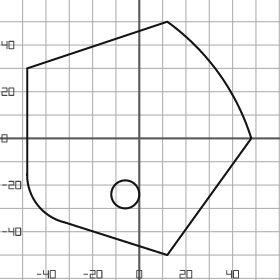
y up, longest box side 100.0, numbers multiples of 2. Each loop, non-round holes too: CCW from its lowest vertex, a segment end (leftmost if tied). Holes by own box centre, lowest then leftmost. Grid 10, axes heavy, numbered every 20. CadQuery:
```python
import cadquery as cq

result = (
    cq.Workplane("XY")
    .moveTo(12.0, -50.0)
    .lineTo(48.0, 0.0)
    .threePointArc((34.0, 28.0), (12.0, 50.0))
    .lineTo(-48.0, 30.0)
    .lineTo(-48.0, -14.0)
    .threePointArc((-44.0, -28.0), (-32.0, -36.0))
    .close()
    .moveTo(-6.0, -24.0)
    .circle(6.0)
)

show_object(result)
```